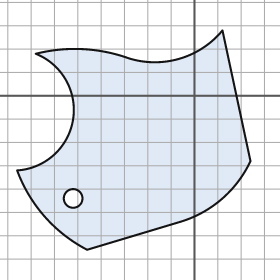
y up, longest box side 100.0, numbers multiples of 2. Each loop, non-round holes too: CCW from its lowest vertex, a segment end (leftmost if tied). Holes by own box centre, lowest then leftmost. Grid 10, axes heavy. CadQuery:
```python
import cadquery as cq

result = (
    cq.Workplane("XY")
    .moveTo(-46.0, -66.0)
    .lineTo(-6.0, -54.0)
    .threePointArc((12.0, -44.0), (24.0, -28.0))
    .lineTo(12.0, 28.0)
    .threePointArc((-6.0, 16.0), (-28.0, 16.0))
    .threePointArc((-48.0, 20.0), (-68.0, 18.0))
    .threePointArc((-52.0, -10.0), (-76.0, -32.0))
    .threePointArc((-64.0, -52.0), (-46.0, -66.0))
    .close()
    .moveTo(-52.0, -44.0)
    .circle(4.0)
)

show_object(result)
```